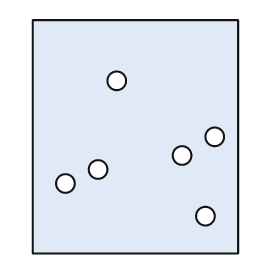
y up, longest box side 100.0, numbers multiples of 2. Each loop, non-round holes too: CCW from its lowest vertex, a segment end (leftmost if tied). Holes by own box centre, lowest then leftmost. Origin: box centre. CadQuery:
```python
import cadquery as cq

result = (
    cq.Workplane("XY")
    .moveTo(-44.0, -50.0)
    .lineTo(44.0, -50.0)
    .lineTo(44.0, 50.0)
    .lineTo(-44.0, 50.0)
    .close()
    .moveTo(30.0, -34.0)
    .circle(4.0)
    .moveTo(-30.0, -20.0)
    .circle(4.0)
    .moveTo(-16.0, -14.0)
    .circle(4.0)
    .moveTo(20.0, -8.0)
    .circle(4.0)
    .moveTo(34.0, 0.0)
    .circle(4.0)
    .moveTo(-8.0, 24.0)
    .circle(4.0)
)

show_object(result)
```